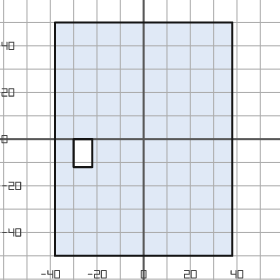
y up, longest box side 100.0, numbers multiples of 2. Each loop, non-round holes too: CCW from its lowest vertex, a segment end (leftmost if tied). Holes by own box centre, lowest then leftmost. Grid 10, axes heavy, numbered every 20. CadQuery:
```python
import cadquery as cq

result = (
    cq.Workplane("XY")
    .moveTo(-38.0, -50.0)
    .lineTo(38.0, -50.0)
    .lineTo(38.0, 50.0)
    .lineTo(-38.0, 50.0)
    .close()
    .moveTo(-30.0, -12.0)
    .lineTo(-22.0, -12.0)
    .lineTo(-22.0, 0.0)
    .lineTo(-30.0, 0.0)
    .close()
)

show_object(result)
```